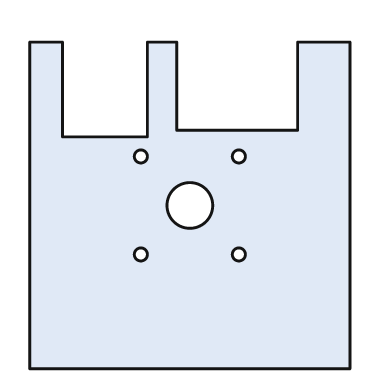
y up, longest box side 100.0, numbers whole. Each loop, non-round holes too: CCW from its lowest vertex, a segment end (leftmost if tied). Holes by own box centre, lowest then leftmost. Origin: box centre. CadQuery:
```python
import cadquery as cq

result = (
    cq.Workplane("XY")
    .moveTo(-49.0, -50.0)
    .lineTo(49.0, -50.0)
    .lineTo(49.0, 50.0)
    .lineTo(33.0, 50.0)
    .lineTo(33.0, 23.0)
    .lineTo(-4.0, 23.0)
    .lineTo(-4.0, 50.0)
    .lineTo(-13.0, 50.0)
    .lineTo(-13.0, 21.0)
    .lineTo(-39.0, 21.0)
    .lineTo(-39.0, 50.0)
    .lineTo(-49.0, 50.0)
    .close()
    .moveTo(-15.0, -15.0)
    .circle(2.0)
    .moveTo(15.0, -15.0)
    .circle(2.0)
    .moveTo(0.0, 0.0)
    .circle(7.0)
    .moveTo(-15.0, 15.0)
    .circle(2.0)
    .moveTo(15.0, 15.0)
    .circle(2.0)
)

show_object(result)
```